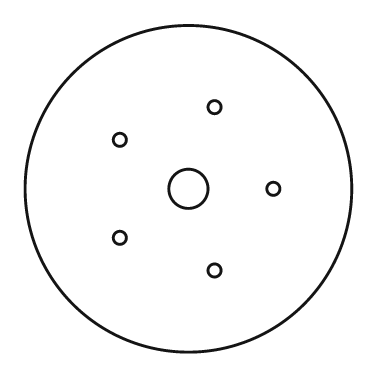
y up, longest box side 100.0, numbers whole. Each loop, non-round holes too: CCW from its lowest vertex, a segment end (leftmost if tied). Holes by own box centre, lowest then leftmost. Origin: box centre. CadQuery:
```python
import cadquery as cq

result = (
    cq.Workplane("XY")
    .moveTo(0.0, 0.0)
    .circle(50.0)
    .moveTo(8.0, -25.0)
    .circle(2.0)
    .moveTo(-21.0, -15.0)
    .circle(2.0)
    .moveTo(0.0, 0.0)
    .circle(6.0)
    .moveTo(26.0, 0.0)
    .circle(2.0)
    .moveTo(-21.0, 15.0)
    .circle(2.0)
    .moveTo(8.0, 25.0)
    .circle(2.0)
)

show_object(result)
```